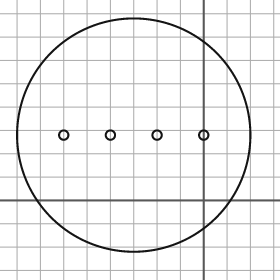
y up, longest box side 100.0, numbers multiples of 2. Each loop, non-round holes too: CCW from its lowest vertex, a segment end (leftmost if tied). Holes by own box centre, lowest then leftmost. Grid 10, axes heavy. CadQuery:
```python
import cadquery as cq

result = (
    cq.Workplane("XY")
    .moveTo(-30.0, 28.0)
    .circle(50.0)
    .moveTo(-60.0, 28.0)
    .circle(2.0)
    .moveTo(-40.0, 28.0)
    .circle(2.0)
    .moveTo(-20.0, 28.0)
    .circle(2.0)
    .moveTo(0.0, 28.0)
    .circle(2.0)
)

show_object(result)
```